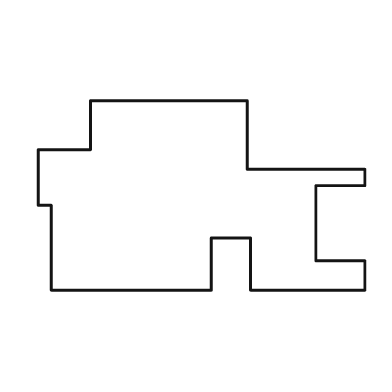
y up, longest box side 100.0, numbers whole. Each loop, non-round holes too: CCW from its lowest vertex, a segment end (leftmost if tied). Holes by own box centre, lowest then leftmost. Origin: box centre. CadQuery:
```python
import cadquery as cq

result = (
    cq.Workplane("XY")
    .moveTo(-46.0, -29.0)
    .lineTo(3.0, -29.0)
    .lineTo(3.0, -13.0)
    .lineTo(15.0, -13.0)
    .lineTo(15.0, -29.0)
    .lineTo(50.0, -29.0)
    .lineTo(50.0, -20.0)
    .lineTo(35.0, -20.0)
    .lineTo(35.0, 3.0)
    .lineTo(50.0, 3.0)
    .lineTo(50.0, 8.0)
    .lineTo(14.0, 8.0)
    .lineTo(14.0, 29.0)
    .lineTo(-34.0, 29.0)
    .lineTo(-34.0, 14.0)
    .lineTo(-50.0, 14.0)
    .lineTo(-50.0, -3.0)
    .lineTo(-46.0, -3.0)
    .close()
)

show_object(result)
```